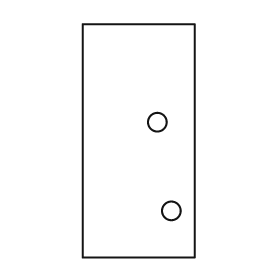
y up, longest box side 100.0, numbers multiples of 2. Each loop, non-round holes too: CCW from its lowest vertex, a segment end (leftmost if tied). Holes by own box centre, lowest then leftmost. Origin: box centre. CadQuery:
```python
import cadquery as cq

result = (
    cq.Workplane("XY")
    .moveTo(-24.0, -50.0)
    .lineTo(24.0, -50.0)
    .lineTo(24.0, 50.0)
    .lineTo(-24.0, 50.0)
    .close()
    .moveTo(14.0, -30.0)
    .circle(4.0)
    .moveTo(8.0, 8.0)
    .circle(4.0)
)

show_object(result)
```